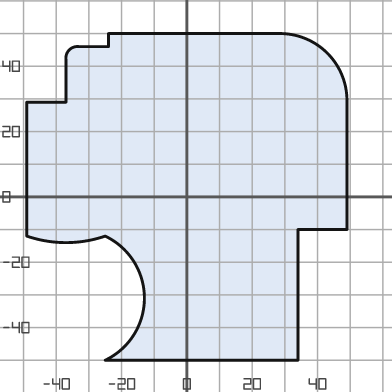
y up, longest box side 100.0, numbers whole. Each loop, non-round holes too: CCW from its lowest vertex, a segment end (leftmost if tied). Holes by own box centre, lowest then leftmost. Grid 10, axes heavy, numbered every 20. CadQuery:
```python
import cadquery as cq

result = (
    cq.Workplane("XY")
    .moveTo(-25.0, -50.0)
    .lineTo(34.0, -50.0)
    .lineTo(34.0, -10.0)
    .lineTo(49.0, -10.0)
    .lineTo(49.0, 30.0)
    .threePointArc((43.0, 44.0), (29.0, 50.0))
    .lineTo(-24.0, 50.0)
    .lineTo(-24.0, 46.0)
    .lineTo(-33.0, 46.0)
    .threePointArc((-36.0, 45.0), (-37.0, 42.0))
    .lineTo(-37.0, 29.0)
    .lineTo(-49.0, 29.0)
    .lineTo(-49.0, -12.0)
    .threePointArc((-37.0, -14.0), (-25.0, -12.0))
    .threePointArc((-13.0, -31.0), (-25.0, -50.0))
    .close()
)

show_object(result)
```